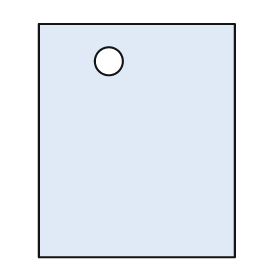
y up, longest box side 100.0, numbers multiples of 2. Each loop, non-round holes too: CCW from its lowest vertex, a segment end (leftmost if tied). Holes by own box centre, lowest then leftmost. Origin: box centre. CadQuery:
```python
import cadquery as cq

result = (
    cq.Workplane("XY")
    .moveTo(-42.0, -50.0)
    .lineTo(42.0, -50.0)
    .lineTo(42.0, 50.0)
    .lineTo(-42.0, 50.0)
    .close()
    .moveTo(-12.0, 34.0)
    .circle(6.0)
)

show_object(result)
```